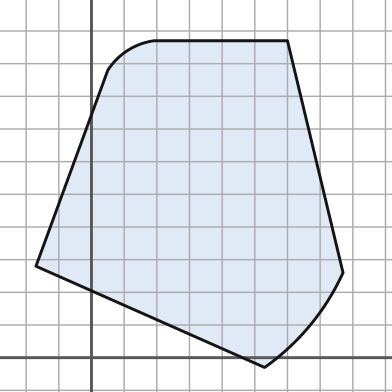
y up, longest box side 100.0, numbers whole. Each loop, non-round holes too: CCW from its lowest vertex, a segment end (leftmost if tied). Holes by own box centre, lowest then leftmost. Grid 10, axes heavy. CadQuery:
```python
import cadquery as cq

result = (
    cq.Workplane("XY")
    .moveTo(53.0, -3.0)
    .threePointArc((67.0, 10.0), (77.0, 26.0))
    .lineTo(60.0, 97.0)
    .lineTo(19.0, 97.0)
    .threePointArc((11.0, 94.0), (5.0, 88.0))
    .lineTo(-17.0, 28.0)
    .close()
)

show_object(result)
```